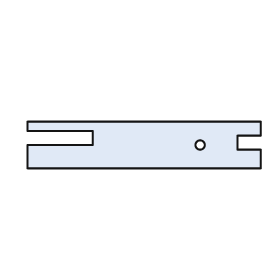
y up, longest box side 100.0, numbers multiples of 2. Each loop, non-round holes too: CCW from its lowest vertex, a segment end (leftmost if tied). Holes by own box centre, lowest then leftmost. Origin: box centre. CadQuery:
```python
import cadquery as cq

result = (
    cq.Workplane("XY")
    .moveTo(-50.0, -10.0)
    .lineTo(50.0, -10.0)
    .lineTo(50.0, -2.0)
    .lineTo(40.0, -2.0)
    .lineTo(40.0, 4.0)
    .lineTo(50.0, 4.0)
    .lineTo(50.0, 10.0)
    .lineTo(-50.0, 10.0)
    .lineTo(-50.0, 6.0)
    .lineTo(-22.0, 6.0)
    .lineTo(-22.0, 0.0)
    .lineTo(-50.0, 0.0)
    .close()
    .moveTo(24.0, 0.0)
    .circle(2.0)
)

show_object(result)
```